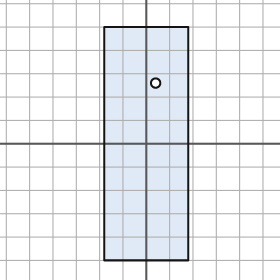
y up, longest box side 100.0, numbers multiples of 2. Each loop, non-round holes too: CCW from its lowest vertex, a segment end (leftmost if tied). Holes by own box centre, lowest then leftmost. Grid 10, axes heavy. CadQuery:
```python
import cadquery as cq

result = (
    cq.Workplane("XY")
    .moveTo(-18.0, -50.0)
    .lineTo(18.0, -50.0)
    .lineTo(18.0, 50.0)
    .lineTo(-18.0, 50.0)
    .close()
    .moveTo(4.0, 26.0)
    .circle(2.0)
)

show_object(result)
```